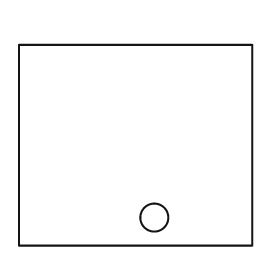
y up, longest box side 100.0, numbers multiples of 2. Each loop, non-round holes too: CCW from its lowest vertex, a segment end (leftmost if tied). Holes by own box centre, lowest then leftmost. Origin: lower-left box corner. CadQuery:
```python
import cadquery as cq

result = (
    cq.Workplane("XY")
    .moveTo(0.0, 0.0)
    .lineTo(100.0, 0.0)
    .lineTo(100.0, 86.0)
    .lineTo(0.0, 86.0)
    .close()
    .moveTo(58.0, 12.0)
    .circle(6.0)
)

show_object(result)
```